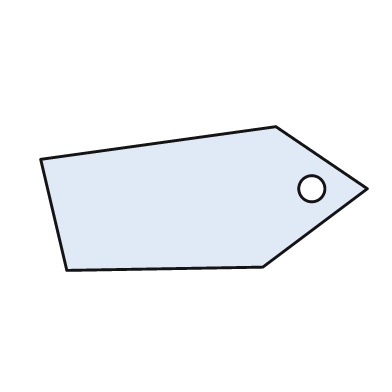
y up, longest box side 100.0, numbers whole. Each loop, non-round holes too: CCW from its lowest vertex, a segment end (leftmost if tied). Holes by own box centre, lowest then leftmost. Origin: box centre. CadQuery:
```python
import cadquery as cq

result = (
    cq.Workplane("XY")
    .moveTo(-42.0, -22.0)
    .lineTo(18.0, -21.0)
    .lineTo(50.0, 3.0)
    .lineTo(22.0, 22.0)
    .lineTo(-50.0, 12.0)
    .close()
    .moveTo(33.0, 3.0)
    .circle(4.0)
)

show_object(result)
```